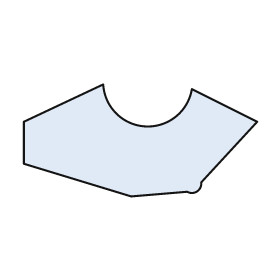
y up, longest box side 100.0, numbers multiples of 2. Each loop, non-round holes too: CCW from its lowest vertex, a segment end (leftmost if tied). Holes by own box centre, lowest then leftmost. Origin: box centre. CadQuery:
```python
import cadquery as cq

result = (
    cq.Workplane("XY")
    .moveTo(-4.0, -24.0)
    .lineTo(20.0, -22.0)
    .threePointArc((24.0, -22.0), (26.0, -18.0))
    .lineTo(50.0, 8.0)
    .lineTo(22.0, 22.0)
    .threePointArc((2.0, 6.0), (-16.0, 24.0))
    .lineTo(-50.0, 8.0)
    .lineTo(-50.0, -10.0)
    .close()
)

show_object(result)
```